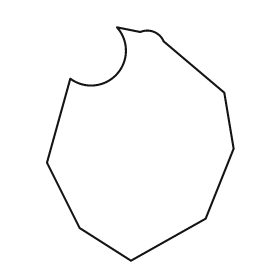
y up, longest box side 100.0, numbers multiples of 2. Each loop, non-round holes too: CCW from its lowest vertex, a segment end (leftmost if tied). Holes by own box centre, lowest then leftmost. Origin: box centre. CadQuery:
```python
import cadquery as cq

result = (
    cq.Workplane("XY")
    .moveTo(-4.0, -50.0)
    .lineTo(28.0, -32.0)
    .lineTo(40.0, -2.0)
    .lineTo(36.0, 22.0)
    .lineTo(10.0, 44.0)
    .threePointArc((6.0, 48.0), (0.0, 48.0))
    .lineTo(-10.0, 50.0)
    .threePointArc((-10.0, 30.0), (-30.0, 28.0))
    .lineTo(-40.0, -8.0)
    .lineTo(-26.0, -36.0)
    .close()
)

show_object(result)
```